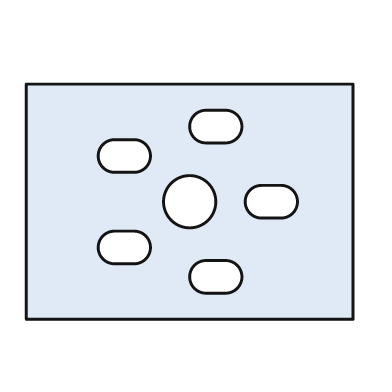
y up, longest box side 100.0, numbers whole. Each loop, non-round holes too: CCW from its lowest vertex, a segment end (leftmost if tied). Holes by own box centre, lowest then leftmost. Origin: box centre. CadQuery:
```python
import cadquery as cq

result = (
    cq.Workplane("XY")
    .moveTo(-50.0, -36.0)
    .lineTo(50.0, -36.0)
    .lineTo(50.0, 36.0)
    .lineTo(-50.0, 36.0)
    .close()
    .moveTo(5.0, -28.0)
    .lineTo(11.0, -28.0)
    .threePointArc((16.0, -23.0), (11.0, -18.0))
    .lineTo(5.0, -18.0)
    .threePointArc((0.0, -23.0), (5.0, -28.0))
    .close()
    .moveTo(-23.0, -19.0)
    .lineTo(-17.0, -19.0)
    .threePointArc((-12.0, -14.0), (-17.0, -9.0))
    .lineTo(-23.0, -9.0)
    .threePointArc((-28.0, -14.0), (-23.0, -19.0))
    .close()
    .moveTo(0.0, 0.0)
    .circle(8.0)
    .moveTo(22.0, -5.0)
    .lineTo(28.0, -5.0)
    .threePointArc((33.0, 0.0), (28.0, 5.0))
    .lineTo(22.0, 5.0)
    .threePointArc((17.0, 0.0), (22.0, -5.0))
    .close()
    .moveTo(-23.0, 9.0)
    .lineTo(-17.0, 9.0)
    .threePointArc((-12.0, 14.0), (-17.0, 19.0))
    .lineTo(-23.0, 19.0)
    .threePointArc((-28.0, 14.0), (-23.0, 9.0))
    .close()
    .moveTo(5.0, 18.0)
    .lineTo(11.0, 18.0)
    .threePointArc((16.0, 23.0), (11.0, 28.0))
    .lineTo(5.0, 28.0)
    .threePointArc((0.0, 23.0), (5.0, 18.0))
    .close()
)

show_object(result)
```